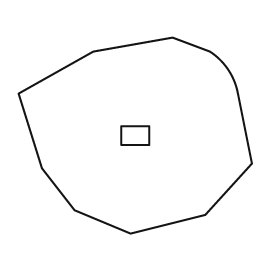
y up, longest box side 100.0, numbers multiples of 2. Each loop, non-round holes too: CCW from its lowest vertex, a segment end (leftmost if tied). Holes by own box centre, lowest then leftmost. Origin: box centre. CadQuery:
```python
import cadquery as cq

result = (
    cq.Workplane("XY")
    .moveTo(-2.0, -42.0)
    .lineTo(30.0, -34.0)
    .lineTo(50.0, -12.0)
    .lineTo(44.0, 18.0)
    .threePointArc((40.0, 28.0), (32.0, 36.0))
    .lineTo(16.0, 42.0)
    .lineTo(-18.0, 36.0)
    .lineTo(-50.0, 18.0)
    .lineTo(-40.0, -14.0)
    .lineTo(-26.0, -32.0)
    .close()
    .moveTo(-6.0, -4.0)
    .lineTo(6.0, -4.0)
    .lineTo(6.0, 4.0)
    .lineTo(-6.0, 4.0)
    .close()
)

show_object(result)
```